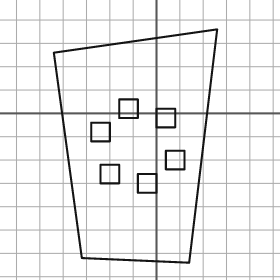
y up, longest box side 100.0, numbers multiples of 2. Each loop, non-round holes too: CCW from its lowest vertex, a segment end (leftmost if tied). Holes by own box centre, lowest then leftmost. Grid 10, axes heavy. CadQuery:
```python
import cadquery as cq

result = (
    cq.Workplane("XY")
    .moveTo(14.0, -64.0)
    .lineTo(26.0, 36.0)
    .lineTo(-44.0, 26.0)
    .lineTo(-32.0, -62.0)
    .close()
    .moveTo(-8.0, -34.0)
    .lineTo(0.0, -34.0)
    .lineTo(0.0, -26.0)
    .lineTo(-8.0, -26.0)
    .close()
    .moveTo(-24.0, -30.0)
    .lineTo(-16.0, -30.0)
    .lineTo(-16.0, -22.0)
    .lineTo(-24.0, -22.0)
    .close()
    .moveTo(4.0, -24.0)
    .lineTo(12.0, -24.0)
    .lineTo(12.0, -16.0)
    .lineTo(4.0, -16.0)
    .close()
    .moveTo(-28.0, -12.0)
    .lineTo(-20.0, -12.0)
    .lineTo(-20.0, -4.0)
    .lineTo(-28.0, -4.0)
    .close()
    .moveTo(0.0, -6.0)
    .lineTo(8.0, -6.0)
    .lineTo(8.0, 2.0)
    .lineTo(0.0, 2.0)
    .close()
    .moveTo(-16.0, -2.0)
    .lineTo(-8.0, -2.0)
    .lineTo(-8.0, 6.0)
    .lineTo(-16.0, 6.0)
    .close()
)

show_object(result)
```